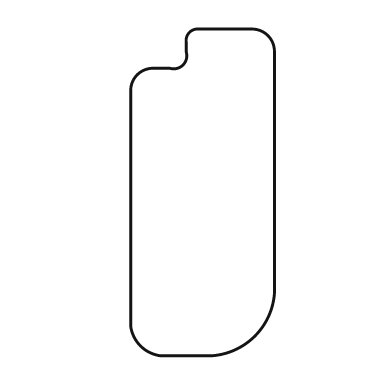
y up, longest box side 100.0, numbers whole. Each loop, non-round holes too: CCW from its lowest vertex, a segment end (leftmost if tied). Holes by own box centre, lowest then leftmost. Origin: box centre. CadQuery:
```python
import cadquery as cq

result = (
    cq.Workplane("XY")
    .moveTo(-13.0, -50.0)
    .lineTo(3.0, -50.0)
    .threePointArc((16.0, -44.0), (22.0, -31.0))
    .lineTo(22.0, 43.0)
    .threePointArc((20.0, 48.0), (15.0, 50.0))
    .lineTo(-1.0, 50.0)
    .threePointArc((-4.0, 49.0), (-5.0, 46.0))
    .lineTo(-5.0, 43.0)
    .threePointArc((-6.0, 39.0), (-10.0, 38.0))
    .lineTo(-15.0, 38.0)
    .threePointArc((-20.0, 36.0), (-22.0, 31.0))
    .lineTo(-22.0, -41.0)
    .threePointArc((-19.0, -47.0), (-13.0, -50.0))
    .close()
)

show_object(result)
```